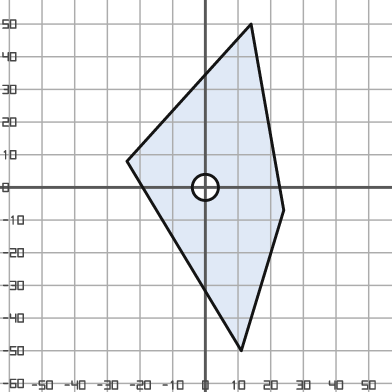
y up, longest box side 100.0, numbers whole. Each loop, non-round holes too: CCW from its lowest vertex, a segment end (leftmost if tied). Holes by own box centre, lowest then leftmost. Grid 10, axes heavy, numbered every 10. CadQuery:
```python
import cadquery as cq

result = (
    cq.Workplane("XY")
    .moveTo(11.0, -50.0)
    .lineTo(24.0, -7.0)
    .lineTo(14.0, 50.0)
    .lineTo(-24.0, 8.0)
    .close()
    .moveTo(0.0, 0.0)
    .circle(4.0)
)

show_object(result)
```